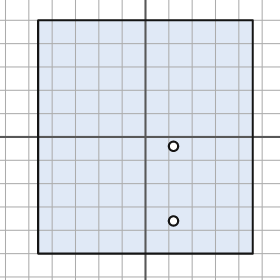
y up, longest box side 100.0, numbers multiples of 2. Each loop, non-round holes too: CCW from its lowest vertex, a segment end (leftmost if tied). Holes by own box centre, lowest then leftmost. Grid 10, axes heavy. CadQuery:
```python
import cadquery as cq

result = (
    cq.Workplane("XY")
    .moveTo(-46.0, -50.0)
    .lineTo(46.0, -50.0)
    .lineTo(46.0, 50.0)
    .lineTo(-46.0, 50.0)
    .close()
    .moveTo(12.0, -36.0)
    .circle(2.0)
    .moveTo(12.0, -4.0)
    .circle(2.0)
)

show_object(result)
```